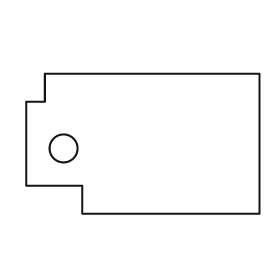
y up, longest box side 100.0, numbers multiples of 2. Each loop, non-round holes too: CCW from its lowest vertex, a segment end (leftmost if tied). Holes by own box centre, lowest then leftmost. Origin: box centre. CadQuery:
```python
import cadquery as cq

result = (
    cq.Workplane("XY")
    .moveTo(-26.0, -30.0)
    .lineTo(50.0, -30.0)
    .lineTo(50.0, 30.0)
    .lineTo(-42.0, 30.0)
    .lineTo(-42.0, 18.0)
    .lineTo(-50.0, 18.0)
    .lineTo(-50.0, -18.0)
    .lineTo(-26.0, -18.0)
    .close()
    .moveTo(-34.0, -2.0)
    .circle(6.0)
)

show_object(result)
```